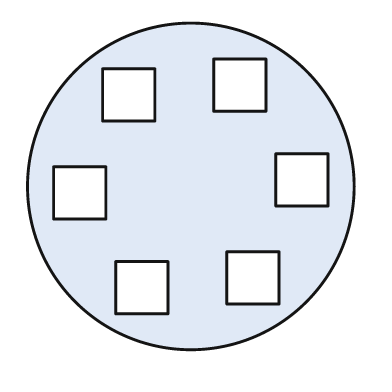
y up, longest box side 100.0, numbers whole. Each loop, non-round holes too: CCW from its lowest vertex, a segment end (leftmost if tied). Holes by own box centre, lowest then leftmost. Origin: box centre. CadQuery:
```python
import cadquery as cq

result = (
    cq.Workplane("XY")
    .moveTo(0.0, 0.0)
    .circle(50.0)
    .moveTo(-23.0, -39.0)
    .lineTo(-7.0, -39.0)
    .lineTo(-7.0, -23.0)
    .lineTo(-23.0, -23.0)
    .close()
    .moveTo(11.0, -36.0)
    .lineTo(27.0, -36.0)
    .lineTo(27.0, -20.0)
    .lineTo(11.0, -20.0)
    .close()
    .moveTo(-42.0, -10.0)
    .lineTo(-26.0, -10.0)
    .lineTo(-26.0, 6.0)
    .lineTo(-42.0, 6.0)
    .close()
    .moveTo(26.0, -6.0)
    .lineTo(42.0, -6.0)
    .lineTo(42.0, 10.0)
    .lineTo(26.0, 10.0)
    .close()
    .moveTo(-27.0, 20.0)
    .lineTo(-11.0, 20.0)
    .lineTo(-11.0, 36.0)
    .lineTo(-27.0, 36.0)
    .close()
    .moveTo(7.0, 23.0)
    .lineTo(23.0, 23.0)
    .lineTo(23.0, 39.0)
    .lineTo(7.0, 39.0)
    .close()
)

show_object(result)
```